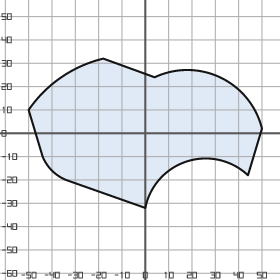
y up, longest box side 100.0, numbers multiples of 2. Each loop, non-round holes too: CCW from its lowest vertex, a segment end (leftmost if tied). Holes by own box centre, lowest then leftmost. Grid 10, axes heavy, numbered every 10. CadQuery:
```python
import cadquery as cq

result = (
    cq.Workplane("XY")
    .moveTo(0.0, -32.0)
    .threePointArc((18.0, -12.0), (44.0, -18.0))
    .lineTo(50.0, 2.0)
    .threePointArc((32.0, 24.0), (4.0, 24.0))
    .lineTo(-18.0, 32.0)
    .threePointArc((-36.0, 24.0), (-50.0, 10.0))
    .lineTo(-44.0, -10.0)
    .threePointArc((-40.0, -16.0), (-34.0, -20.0))
    .close()
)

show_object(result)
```